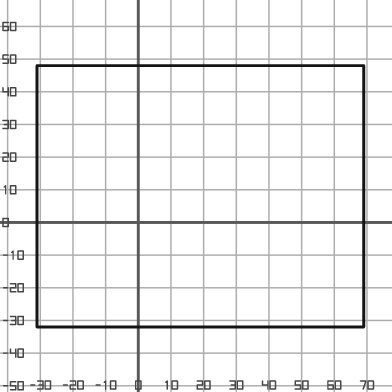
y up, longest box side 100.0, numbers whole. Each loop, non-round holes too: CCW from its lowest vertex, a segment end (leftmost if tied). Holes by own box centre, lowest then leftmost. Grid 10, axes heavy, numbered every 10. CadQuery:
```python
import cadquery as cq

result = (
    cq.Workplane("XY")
    .moveTo(-31.0, -32.0)
    .lineTo(69.0, -32.0)
    .lineTo(69.0, 48.0)
    .lineTo(-31.0, 48.0)
    .close()
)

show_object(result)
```